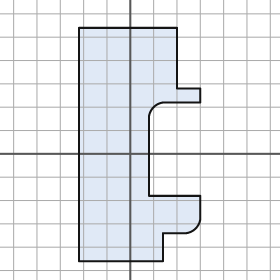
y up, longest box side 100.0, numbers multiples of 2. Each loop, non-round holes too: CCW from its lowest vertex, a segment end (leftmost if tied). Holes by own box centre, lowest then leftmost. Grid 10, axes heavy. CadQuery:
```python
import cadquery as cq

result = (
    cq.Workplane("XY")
    .moveTo(-22.0, -46.0)
    .lineTo(14.0, -46.0)
    .lineTo(14.0, -34.0)
    .lineTo(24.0, -34.0)
    .threePointArc((28.0, -32.0), (30.0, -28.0))
    .lineTo(30.0, -18.0)
    .lineTo(8.0, -18.0)
    .lineTo(8.0, 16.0)
    .threePointArc((10.0, 20.0), (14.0, 22.0))
    .lineTo(30.0, 22.0)
    .lineTo(30.0, 28.0)
    .lineTo(20.0, 28.0)
    .lineTo(20.0, 54.0)
    .lineTo(-22.0, 54.0)
    .close()
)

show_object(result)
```